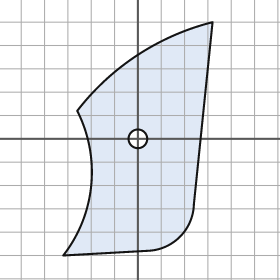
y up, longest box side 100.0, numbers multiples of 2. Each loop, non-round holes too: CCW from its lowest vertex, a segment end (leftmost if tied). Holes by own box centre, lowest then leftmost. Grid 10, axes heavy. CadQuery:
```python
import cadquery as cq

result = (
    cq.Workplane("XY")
    .moveTo(-32.0, -50.0)
    .lineTo(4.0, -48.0)
    .threePointArc((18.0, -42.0), (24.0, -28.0))
    .lineTo(32.0, 50.0)
    .threePointArc((0.0, 36.0), (-26.0, 12.0))
    .threePointArc((-20.0, -20.0), (-32.0, -50.0))
    .close()
    .moveTo(0.0, 0.0)
    .circle(4.0)
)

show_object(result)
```